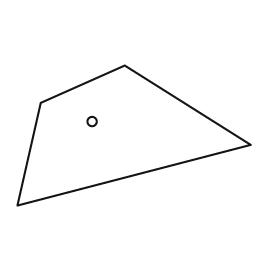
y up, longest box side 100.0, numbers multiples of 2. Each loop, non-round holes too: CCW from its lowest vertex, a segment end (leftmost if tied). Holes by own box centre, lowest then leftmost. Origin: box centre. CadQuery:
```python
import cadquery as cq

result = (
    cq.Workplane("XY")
    .moveTo(-50.0, -30.0)
    .lineTo(50.0, -4.0)
    .lineTo(-4.0, 30.0)
    .lineTo(-40.0, 14.0)
    .close()
    .moveTo(-18.0, 6.0)
    .circle(2.0)
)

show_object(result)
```